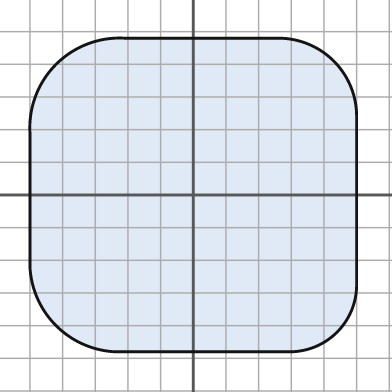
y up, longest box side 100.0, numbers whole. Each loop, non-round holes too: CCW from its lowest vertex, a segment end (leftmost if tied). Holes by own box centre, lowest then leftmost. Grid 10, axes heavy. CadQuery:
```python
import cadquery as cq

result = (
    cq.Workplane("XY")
    .moveTo(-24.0, -48.0)
    .lineTo(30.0, -48.0)
    .threePointArc((44.0, -42.0), (50.0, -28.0))
    .lineTo(50.0, 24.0)
    .threePointArc((43.0, 41.0), (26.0, 48.0))
    .lineTo(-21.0, 48.0)
    .threePointArc((-42.0, 40.0), (-50.0, 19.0))
    .lineTo(-50.0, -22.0)
    .threePointArc((-42.0, -40.0), (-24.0, -48.0))
    .close()
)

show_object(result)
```